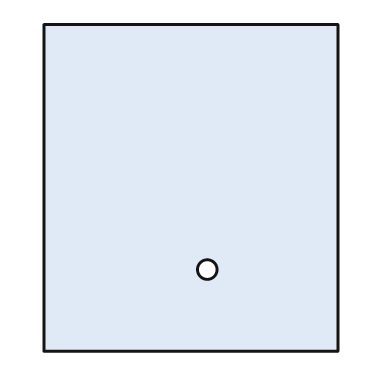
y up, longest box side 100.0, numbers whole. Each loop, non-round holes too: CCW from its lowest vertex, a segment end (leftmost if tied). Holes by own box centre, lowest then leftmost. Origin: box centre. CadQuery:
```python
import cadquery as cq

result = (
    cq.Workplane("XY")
    .moveTo(-45.0, -50.0)
    .lineTo(45.0, -50.0)
    .lineTo(45.0, 50.0)
    .lineTo(-45.0, 50.0)
    .close()
    .moveTo(5.0, -25.0)
    .circle(3.0)
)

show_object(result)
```